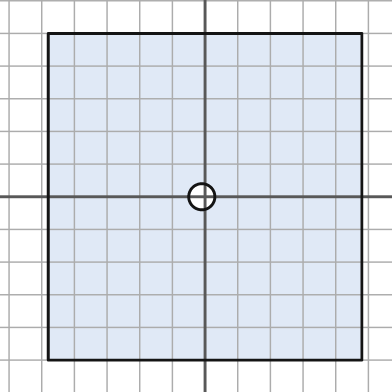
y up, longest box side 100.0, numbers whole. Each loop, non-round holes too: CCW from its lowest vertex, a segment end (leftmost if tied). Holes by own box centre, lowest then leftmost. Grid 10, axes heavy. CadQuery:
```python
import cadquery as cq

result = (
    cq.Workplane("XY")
    .moveTo(-48.0, -50.0)
    .lineTo(48.0, -50.0)
    .lineTo(48.0, 50.0)
    .lineTo(-48.0, 50.0)
    .close()
    .moveTo(-1.0, 0.0)
    .circle(4.0)
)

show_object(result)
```